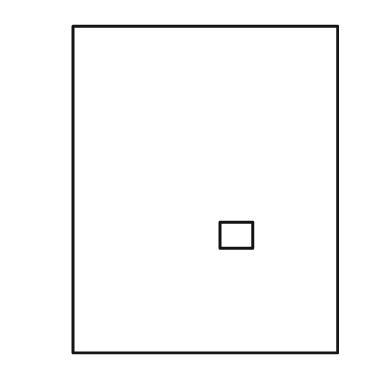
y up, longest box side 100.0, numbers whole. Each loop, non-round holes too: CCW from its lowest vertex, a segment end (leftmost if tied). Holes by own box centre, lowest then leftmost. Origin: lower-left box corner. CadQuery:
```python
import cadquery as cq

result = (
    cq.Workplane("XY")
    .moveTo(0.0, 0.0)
    .lineTo(81.0, 0.0)
    .lineTo(81.0, 100.0)
    .lineTo(0.0, 100.0)
    .close()
    .moveTo(45.0, 32.0)
    .lineTo(55.0, 32.0)
    .lineTo(55.0, 40.0)
    .lineTo(45.0, 40.0)
    .close()
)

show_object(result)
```